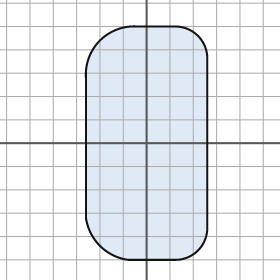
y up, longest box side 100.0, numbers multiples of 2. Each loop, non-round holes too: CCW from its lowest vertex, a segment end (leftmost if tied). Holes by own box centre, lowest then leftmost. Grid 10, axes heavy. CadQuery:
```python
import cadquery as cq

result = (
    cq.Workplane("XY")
    .moveTo(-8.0, -50.0)
    .lineTo(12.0, -50.0)
    .threePointArc((22.0, -46.0), (26.0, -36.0))
    .lineTo(26.0, 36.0)
    .threePointArc((22.0, 46.0), (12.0, 50.0))
    .lineTo(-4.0, 50.0)
    .threePointArc((-20.0, 44.0), (-26.0, 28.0))
    .lineTo(-26.0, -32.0)
    .threePointArc((-20.0, -44.0), (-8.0, -50.0))
    .close()
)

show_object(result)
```